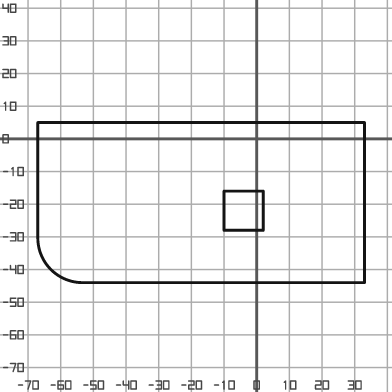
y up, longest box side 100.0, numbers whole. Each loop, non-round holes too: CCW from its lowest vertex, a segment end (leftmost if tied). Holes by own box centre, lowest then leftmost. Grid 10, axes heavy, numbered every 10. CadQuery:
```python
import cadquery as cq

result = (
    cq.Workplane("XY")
    .moveTo(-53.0, -44.0)
    .lineTo(33.0, -44.0)
    .lineTo(33.0, 5.0)
    .lineTo(-67.0, 5.0)
    .lineTo(-67.0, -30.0)
    .threePointArc((-63.0, -40.0), (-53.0, -44.0))
    .close()
    .moveTo(-10.0, -28.0)
    .lineTo(2.0, -28.0)
    .lineTo(2.0, -16.0)
    .lineTo(-10.0, -16.0)
    .close()
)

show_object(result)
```